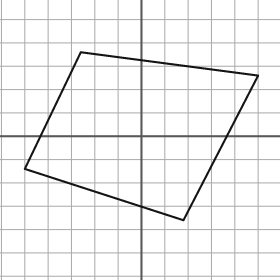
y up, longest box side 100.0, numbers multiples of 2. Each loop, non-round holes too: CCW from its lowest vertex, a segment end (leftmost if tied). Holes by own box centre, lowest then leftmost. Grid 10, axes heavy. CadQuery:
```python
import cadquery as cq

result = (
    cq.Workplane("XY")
    .moveTo(18.0, -36.0)
    .lineTo(50.0, 26.0)
    .lineTo(-26.0, 36.0)
    .lineTo(-50.0, -14.0)
    .close()
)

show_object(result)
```